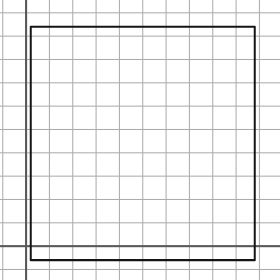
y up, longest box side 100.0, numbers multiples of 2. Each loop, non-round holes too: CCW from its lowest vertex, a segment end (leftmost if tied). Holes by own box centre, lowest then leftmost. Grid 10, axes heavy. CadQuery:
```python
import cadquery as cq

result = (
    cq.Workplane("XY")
    .moveTo(2.0, -6.0)
    .lineTo(98.0, -6.0)
    .lineTo(98.0, 94.0)
    .lineTo(2.0, 94.0)
    .close()
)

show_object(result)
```